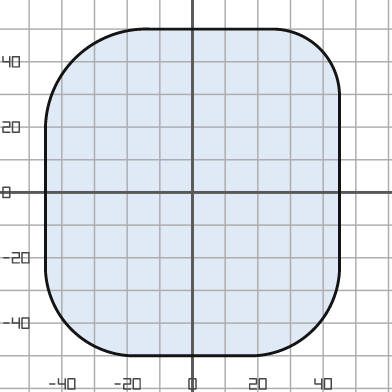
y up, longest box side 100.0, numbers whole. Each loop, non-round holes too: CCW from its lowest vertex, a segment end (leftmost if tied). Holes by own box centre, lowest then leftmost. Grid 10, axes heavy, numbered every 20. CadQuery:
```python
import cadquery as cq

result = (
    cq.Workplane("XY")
    .moveTo(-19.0, -50.0)
    .lineTo(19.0, -50.0)
    .threePointArc((37.0, -42.0), (45.0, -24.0))
    .lineTo(45.0, 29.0)
    .threePointArc((39.0, 44.0), (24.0, 50.0))
    .lineTo(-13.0, 50.0)
    .threePointArc((-36.0, 41.0), (-45.0, 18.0))
    .lineTo(-45.0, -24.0)
    .threePointArc((-37.0, -42.0), (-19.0, -50.0))
    .close()
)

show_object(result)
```